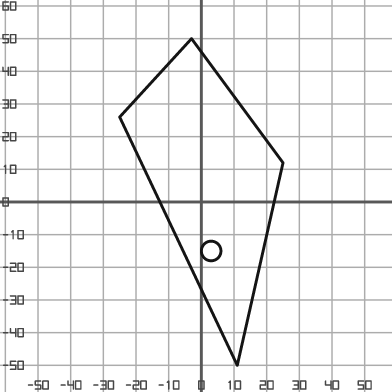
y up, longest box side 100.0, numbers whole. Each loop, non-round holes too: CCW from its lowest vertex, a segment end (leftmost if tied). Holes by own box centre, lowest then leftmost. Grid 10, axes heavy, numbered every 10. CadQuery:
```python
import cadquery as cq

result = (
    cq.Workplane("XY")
    .moveTo(11.0, -50.0)
    .lineTo(25.0, 12.0)
    .lineTo(-3.0, 50.0)
    .lineTo(-25.0, 26.0)
    .close()
    .moveTo(3.0, -15.0)
    .circle(3.0)
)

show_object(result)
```